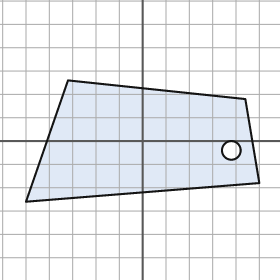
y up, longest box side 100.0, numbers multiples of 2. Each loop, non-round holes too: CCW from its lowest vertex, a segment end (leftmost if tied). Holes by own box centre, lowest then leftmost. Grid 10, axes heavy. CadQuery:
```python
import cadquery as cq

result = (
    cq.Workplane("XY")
    .moveTo(-50.0, -26.0)
    .lineTo(50.0, -18.0)
    .lineTo(44.0, 18.0)
    .lineTo(-32.0, 26.0)
    .close()
    .moveTo(38.0, -4.0)
    .circle(4.0)
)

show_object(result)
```